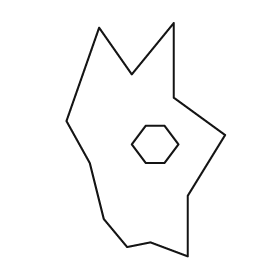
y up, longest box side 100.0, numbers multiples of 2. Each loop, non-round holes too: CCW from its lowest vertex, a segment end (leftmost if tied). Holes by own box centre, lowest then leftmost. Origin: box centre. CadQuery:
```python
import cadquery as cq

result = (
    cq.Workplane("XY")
    .moveTo(18.0, -50.0)
    .lineTo(18.0, -24.0)
    .lineTo(34.0, 2.0)
    .lineTo(12.0, 18.0)
    .lineTo(12.0, 50.0)
    .lineTo(-6.0, 28.0)
    .lineTo(-20.0, 48.0)
    .lineTo(-34.0, 8.0)
    .lineTo(-24.0, -10.0)
    .lineTo(-18.0, -34.0)
    .lineTo(-8.0, -46.0)
    .lineTo(2.0, -44.0)
    .close()
    .moveTo(0.0, -10.0)
    .lineTo(8.0, -10.0)
    .lineTo(14.0, -2.0)
    .lineTo(8.0, 6.0)
    .lineTo(0.0, 6.0)
    .lineTo(-6.0, -2.0)
    .close()
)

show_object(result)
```